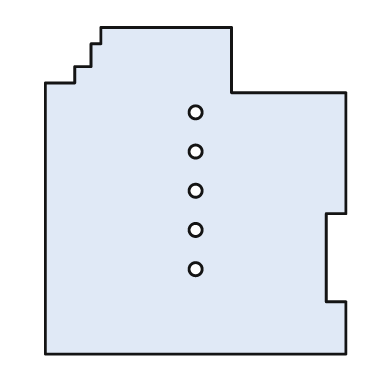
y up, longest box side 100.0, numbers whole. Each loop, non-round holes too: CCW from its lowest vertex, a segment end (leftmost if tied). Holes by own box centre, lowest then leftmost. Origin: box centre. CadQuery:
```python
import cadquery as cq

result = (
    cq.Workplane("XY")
    .moveTo(-46.0, -50.0)
    .lineTo(46.0, -50.0)
    .lineTo(46.0, -34.0)
    .lineTo(40.0, -34.0)
    .lineTo(40.0, -7.0)
    .lineTo(46.0, -7.0)
    .lineTo(46.0, 30.0)
    .lineTo(11.0, 30.0)
    .lineTo(11.0, 50.0)
    .lineTo(-29.0, 50.0)
    .lineTo(-29.0, 45.0)
    .lineTo(-32.0, 45.0)
    .lineTo(-32.0, 38.0)
    .lineTo(-37.0, 38.0)
    .lineTo(-37.0, 33.0)
    .lineTo(-46.0, 33.0)
    .close()
    .moveTo(0.0, -24.0)
    .circle(2.0)
    .moveTo(0.0, -12.0)
    .circle(2.0)
    .moveTo(0.0, 0.0)
    .circle(2.0)
    .moveTo(0.0, 12.0)
    .circle(2.0)
    .moveTo(0.0, 24.0)
    .circle(2.0)
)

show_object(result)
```